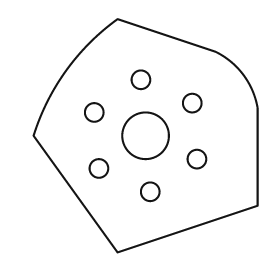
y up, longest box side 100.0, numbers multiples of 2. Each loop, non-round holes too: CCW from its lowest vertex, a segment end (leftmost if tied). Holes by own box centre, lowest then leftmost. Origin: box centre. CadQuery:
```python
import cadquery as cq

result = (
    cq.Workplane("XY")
    .moveTo(-12.0, -50.0)
    .lineTo(48.0, -30.0)
    .lineTo(48.0, 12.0)
    .threePointArc((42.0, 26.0), (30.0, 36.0))
    .lineTo(-12.0, 50.0)
    .threePointArc((-34.0, 28.0), (-48.0, 0.0))
    .close()
    .moveTo(2.0, -24.0)
    .circle(4.0)
    .moveTo(-20.0, -14.0)
    .circle(4.0)
    .moveTo(22.0, -10.0)
    .circle(4.0)
    .moveTo(0.0, 0.0)
    .circle(10.0)
    .moveTo(-22.0, 10.0)
    .circle(4.0)
    .moveTo(20.0, 14.0)
    .circle(4.0)
    .moveTo(-2.0, 24.0)
    .circle(4.0)
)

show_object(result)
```